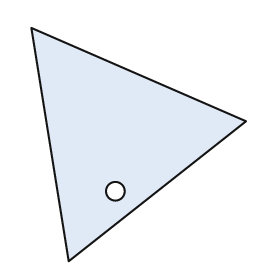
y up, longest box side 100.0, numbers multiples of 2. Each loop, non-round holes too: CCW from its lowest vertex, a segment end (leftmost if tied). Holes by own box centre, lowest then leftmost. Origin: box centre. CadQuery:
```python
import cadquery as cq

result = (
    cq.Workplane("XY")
    .moveTo(-30.0, -50.0)
    .lineTo(46.0, 10.0)
    .lineTo(-46.0, 50.0)
    .close()
    .moveTo(-10.0, -20.0)
    .circle(4.0)
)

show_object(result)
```